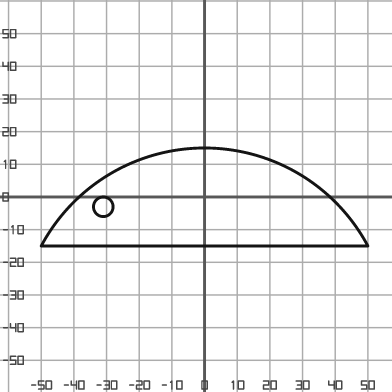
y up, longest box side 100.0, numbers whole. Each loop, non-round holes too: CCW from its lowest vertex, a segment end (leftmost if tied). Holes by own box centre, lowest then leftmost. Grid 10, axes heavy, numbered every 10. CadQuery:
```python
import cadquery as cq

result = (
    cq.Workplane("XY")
    .moveTo(-50.0, -15.0)
    .lineTo(50.0, -15.0)
    .threePointArc((0.0, 15.0), (-50.0, -15.0))
    .close()
    .moveTo(-31.0, -3.0)
    .circle(3.0)
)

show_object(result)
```